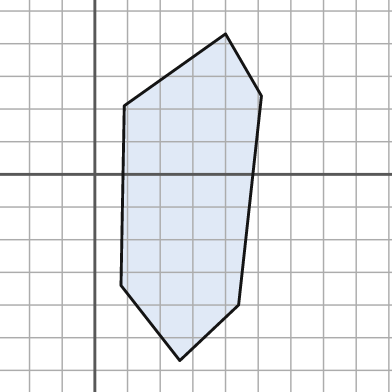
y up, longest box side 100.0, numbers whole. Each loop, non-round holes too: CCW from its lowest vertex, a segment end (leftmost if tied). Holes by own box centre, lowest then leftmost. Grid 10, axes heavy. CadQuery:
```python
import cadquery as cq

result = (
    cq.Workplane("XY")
    .moveTo(26.0, -57.0)
    .lineTo(44.0, -40.0)
    .lineTo(51.0, 24.0)
    .lineTo(40.0, 43.0)
    .lineTo(9.0, 21.0)
    .lineTo(8.0, -34.0)
    .close()
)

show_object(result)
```